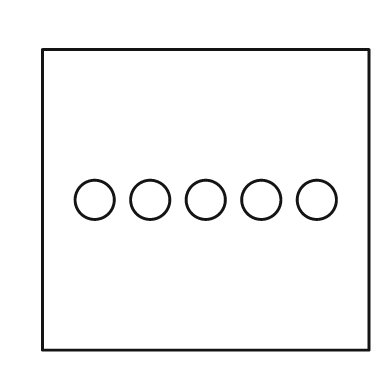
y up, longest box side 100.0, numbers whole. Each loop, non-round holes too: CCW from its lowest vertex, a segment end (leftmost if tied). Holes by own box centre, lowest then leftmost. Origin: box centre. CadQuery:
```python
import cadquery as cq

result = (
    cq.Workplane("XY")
    .moveTo(-50.0, -46.0)
    .lineTo(50.0, -46.0)
    .lineTo(50.0, 46.0)
    .lineTo(-50.0, 46.0)
    .close()
    .moveTo(-34.0, 0.0)
    .circle(6.0)
    .moveTo(-17.0, 0.0)
    .circle(6.0)
    .moveTo(0.0, 0.0)
    .circle(6.0)
    .moveTo(17.0, 0.0)
    .circle(6.0)
    .moveTo(34.0, 0.0)
    .circle(6.0)
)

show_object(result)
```